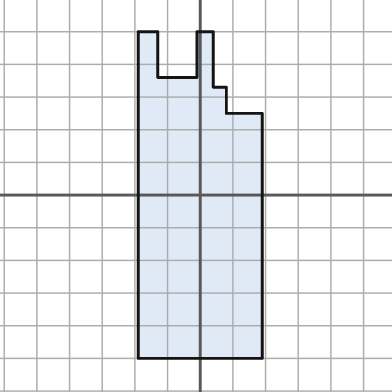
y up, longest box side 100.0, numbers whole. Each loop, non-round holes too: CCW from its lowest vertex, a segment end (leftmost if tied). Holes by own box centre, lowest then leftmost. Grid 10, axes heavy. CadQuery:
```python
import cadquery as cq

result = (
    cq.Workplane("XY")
    .moveTo(-19.0, -50.0)
    .lineTo(19.0, -50.0)
    .lineTo(19.0, 25.0)
    .lineTo(8.0, 25.0)
    .lineTo(8.0, 33.0)
    .lineTo(4.0, 33.0)
    .lineTo(4.0, 50.0)
    .lineTo(-1.0, 50.0)
    .lineTo(-1.0, 36.0)
    .lineTo(-13.0, 36.0)
    .lineTo(-13.0, 50.0)
    .lineTo(-19.0, 50.0)
    .close()
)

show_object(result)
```